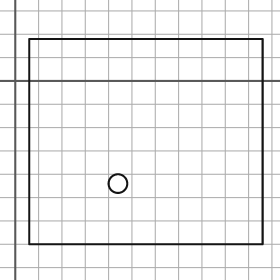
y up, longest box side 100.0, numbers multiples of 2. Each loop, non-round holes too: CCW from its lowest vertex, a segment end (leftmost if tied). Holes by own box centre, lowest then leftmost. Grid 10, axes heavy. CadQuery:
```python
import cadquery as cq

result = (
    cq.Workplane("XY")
    .moveTo(6.0, -70.0)
    .lineTo(106.0, -70.0)
    .lineTo(106.0, 18.0)
    .lineTo(6.0, 18.0)
    .close()
    .moveTo(44.0, -44.0)
    .circle(4.0)
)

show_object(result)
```